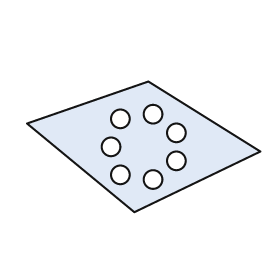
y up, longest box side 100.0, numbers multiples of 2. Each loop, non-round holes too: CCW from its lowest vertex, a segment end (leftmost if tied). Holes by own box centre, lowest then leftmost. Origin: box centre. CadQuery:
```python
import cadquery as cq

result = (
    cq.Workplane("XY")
    .moveTo(-4.0, -28.0)
    .lineTo(50.0, -2.0)
    .lineTo(2.0, 28.0)
    .lineTo(-50.0, 10.0)
    .close()
    .moveTo(4.0, -14.0)
    .circle(4.0)
    .moveTo(-10.0, -12.0)
    .circle(4.0)
    .moveTo(14.0, -6.0)
    .circle(4.0)
    .moveTo(-14.0, 0.0)
    .circle(4.0)
    .moveTo(14.0, 6.0)
    .circle(4.0)
    .moveTo(-10.0, 12.0)
    .circle(4.0)
    .moveTo(4.0, 14.0)
    .circle(4.0)
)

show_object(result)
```